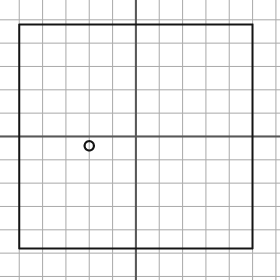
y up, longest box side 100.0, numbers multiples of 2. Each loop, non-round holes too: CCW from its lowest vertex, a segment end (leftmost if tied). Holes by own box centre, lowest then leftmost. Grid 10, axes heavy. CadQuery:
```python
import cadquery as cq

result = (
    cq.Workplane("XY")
    .moveTo(-50.0, -48.0)
    .lineTo(50.0, -48.0)
    .lineTo(50.0, 48.0)
    .lineTo(-50.0, 48.0)
    .close()
    .moveTo(-20.0, -4.0)
    .circle(2.0)
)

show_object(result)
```